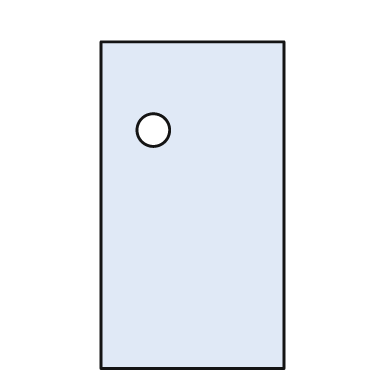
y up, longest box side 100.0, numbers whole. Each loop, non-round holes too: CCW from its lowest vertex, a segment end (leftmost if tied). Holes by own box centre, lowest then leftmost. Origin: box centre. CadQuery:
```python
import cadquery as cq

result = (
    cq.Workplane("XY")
    .moveTo(-28.0, -50.0)
    .lineTo(28.0, -50.0)
    .lineTo(28.0, 50.0)
    .lineTo(-28.0, 50.0)
    .close()
    .moveTo(-12.0, 23.0)
    .circle(5.0)
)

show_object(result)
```